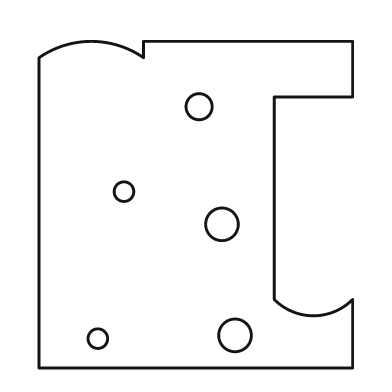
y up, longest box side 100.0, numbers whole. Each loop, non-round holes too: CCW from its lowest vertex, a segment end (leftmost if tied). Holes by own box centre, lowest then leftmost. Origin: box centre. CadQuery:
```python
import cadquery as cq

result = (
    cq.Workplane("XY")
    .moveTo(-48.0, -50.0)
    .lineTo(48.0, -50.0)
    .lineTo(48.0, -29.0)
    .threePointArc((36.0, -34.0), (24.0, -29.0))
    .lineTo(24.0, 33.0)
    .lineTo(48.0, 33.0)
    .lineTo(48.0, 50.0)
    .lineTo(-16.0, 50.0)
    .lineTo(-16.0, 45.0)
    .threePointArc((-32.0, 50.0), (-48.0, 45.0))
    .close()
    .moveTo(-30.0, -41.0)
    .circle(3.0)
    .moveTo(12.0, -40.0)
    .circle(5.0)
    .moveTo(8.0, -6.0)
    .circle(5.0)
    .moveTo(-22.0, 4.0)
    .circle(3.0)
    .moveTo(1.0, 30.0)
    .circle(4.0)
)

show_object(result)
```